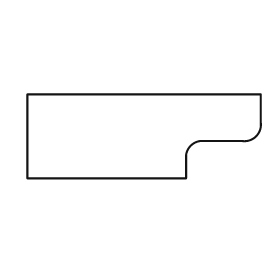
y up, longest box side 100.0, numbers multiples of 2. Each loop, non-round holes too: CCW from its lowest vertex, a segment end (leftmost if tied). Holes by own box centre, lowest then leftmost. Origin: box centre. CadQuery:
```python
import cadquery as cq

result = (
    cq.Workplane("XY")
    .moveTo(-50.0, -18.0)
    .lineTo(18.0, -18.0)
    .lineTo(18.0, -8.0)
    .threePointArc((20.0, -4.0), (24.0, -2.0))
    .lineTo(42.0, -2.0)
    .threePointArc((48.0, 0.0), (50.0, 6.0))
    .lineTo(50.0, 18.0)
    .lineTo(-50.0, 18.0)
    .close()
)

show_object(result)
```